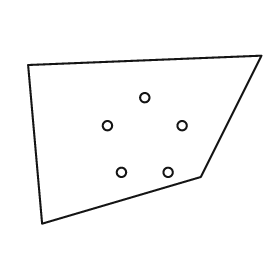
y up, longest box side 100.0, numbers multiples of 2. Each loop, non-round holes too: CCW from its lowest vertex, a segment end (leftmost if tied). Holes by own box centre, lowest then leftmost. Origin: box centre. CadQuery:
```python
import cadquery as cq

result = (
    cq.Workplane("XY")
    .moveTo(-44.0, -36.0)
    .lineTo(24.0, -16.0)
    .lineTo(50.0, 36.0)
    .lineTo(-50.0, 32.0)
    .close()
    .moveTo(-10.0, -14.0)
    .circle(2.0)
    .moveTo(10.0, -14.0)
    .circle(2.0)
    .moveTo(-16.0, 6.0)
    .circle(2.0)
    .moveTo(16.0, 6.0)
    .circle(2.0)
    .moveTo(0.0, 18.0)
    .circle(2.0)
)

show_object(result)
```